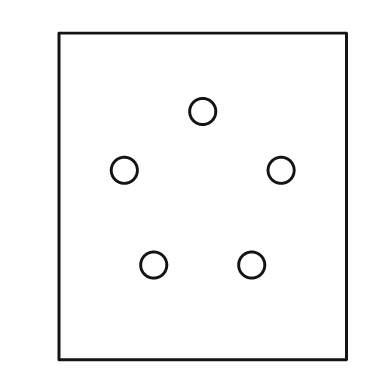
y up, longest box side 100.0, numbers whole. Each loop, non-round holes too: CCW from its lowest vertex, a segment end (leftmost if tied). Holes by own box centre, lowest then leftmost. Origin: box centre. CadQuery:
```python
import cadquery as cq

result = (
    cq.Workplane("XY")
    .moveTo(-44.0, -50.0)
    .lineTo(44.0, -50.0)
    .lineTo(44.0, 50.0)
    .lineTo(-44.0, 50.0)
    .close()
    .moveTo(-15.0, -21.0)
    .circle(4.0)
    .moveTo(15.0, -21.0)
    .circle(4.0)
    .moveTo(-24.0, 8.0)
    .circle(4.0)
    .moveTo(24.0, 8.0)
    .circle(4.0)
    .moveTo(0.0, 26.0)
    .circle(4.0)
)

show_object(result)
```